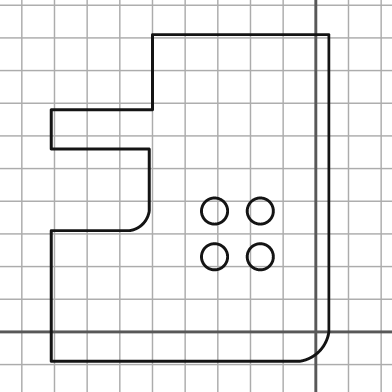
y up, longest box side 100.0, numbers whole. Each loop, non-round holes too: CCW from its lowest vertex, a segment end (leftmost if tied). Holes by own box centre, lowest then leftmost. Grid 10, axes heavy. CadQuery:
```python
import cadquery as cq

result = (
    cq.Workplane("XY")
    .moveTo(-81.0, -9.0)
    .lineTo(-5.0, -9.0)
    .threePointArc((1.0, -6.0), (4.0, 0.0))
    .lineTo(4.0, 91.0)
    .lineTo(-50.0, 91.0)
    .lineTo(-50.0, 68.0)
    .lineTo(-81.0, 68.0)
    .lineTo(-81.0, 56.0)
    .lineTo(-51.0, 56.0)
    .lineTo(-51.0, 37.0)
    .threePointArc((-53.0, 33.0), (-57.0, 31.0))
    .lineTo(-81.0, 31.0)
    .close()
    .moveTo(-31.0, 23.0)
    .circle(4.0)
    .moveTo(-17.0, 23.0)
    .circle(4.0)
    .moveTo(-31.0, 37.0)
    .circle(4.0)
    .moveTo(-17.0, 37.0)
    .circle(4.0)
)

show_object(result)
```